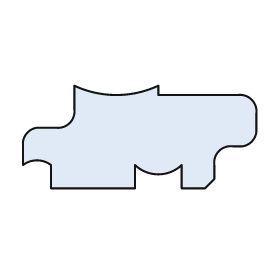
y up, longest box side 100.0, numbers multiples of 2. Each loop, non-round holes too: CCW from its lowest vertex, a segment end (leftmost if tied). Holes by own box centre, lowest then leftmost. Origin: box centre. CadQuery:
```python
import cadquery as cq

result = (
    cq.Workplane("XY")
    .moveTo(-38.0, -22.0)
    .lineTo(-2.0, -22.0)
    .lineTo(-2.0, -12.0)
    .threePointArc((8.0, -16.0), (18.0, -12.0))
    .lineTo(18.0, -22.0)
    .lineTo(28.0, -22.0)
    .lineTo(32.0, -18.0)
    .lineTo(32.0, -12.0)
    .threePointArc((34.0, -6.0), (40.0, -4.0))
    .lineTo(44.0, -4.0)
    .threePointArc((48.0, -2.0), (50.0, 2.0))
    .lineTo(50.0, 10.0)
    .threePointArc((48.0, 16.0), (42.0, 18.0))
    .lineTo(8.0, 18.0)
    .lineTo(8.0, 22.0)
    .threePointArc((-10.0, 18.0), (-28.0, 22.0))
    .lineTo(-28.0, 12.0)
    .threePointArc((-30.0, 6.0), (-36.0, 4.0))
    .lineTo(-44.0, 4.0)
    .threePointArc((-48.0, 2.0), (-50.0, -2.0))
    .lineTo(-50.0, -12.0)
    .threePointArc((-44.0, -10.0), (-38.0, -12.0))
    .close()
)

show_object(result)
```